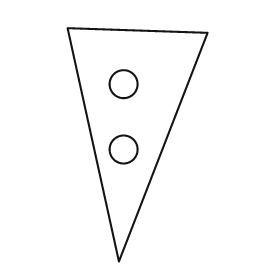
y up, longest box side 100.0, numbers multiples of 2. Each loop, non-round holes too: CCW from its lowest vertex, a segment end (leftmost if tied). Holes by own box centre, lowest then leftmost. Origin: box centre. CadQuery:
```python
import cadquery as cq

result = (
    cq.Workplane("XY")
    .moveTo(-8.0, -50.0)
    .lineTo(30.0, 48.0)
    .lineTo(-30.0, 50.0)
    .close()
    .moveTo(-6.0, -2.0)
    .circle(6.0)
    .moveTo(-6.0, 26.0)
    .circle(6.0)
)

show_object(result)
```